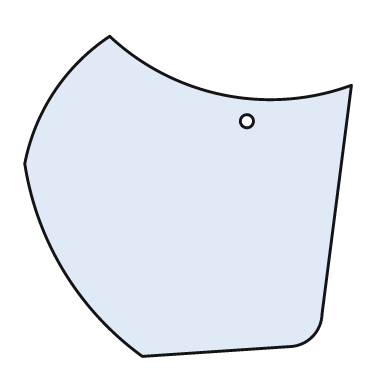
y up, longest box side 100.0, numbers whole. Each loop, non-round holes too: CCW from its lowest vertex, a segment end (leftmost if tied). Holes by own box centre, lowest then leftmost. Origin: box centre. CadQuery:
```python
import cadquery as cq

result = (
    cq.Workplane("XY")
    .moveTo(-14.0, -49.0)
    .lineTo(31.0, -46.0)
    .threePointArc((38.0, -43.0), (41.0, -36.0))
    .lineTo(50.0, 34.0)
    .threePointArc((11.0, 31.0), (-24.0, 49.0))
    .threePointArc((-41.0, 32.0), (-50.0, 10.0))
    .threePointArc((-38.0, -23.0), (-14.0, -49.0))
    .close()
    .moveTo(18.0, 23.0)
    .circle(2.0)
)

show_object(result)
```